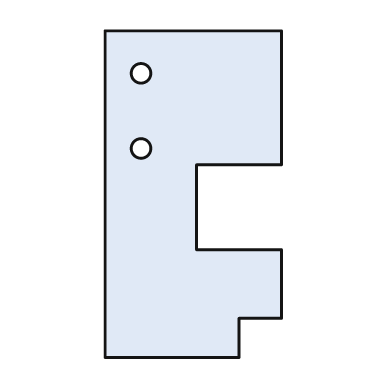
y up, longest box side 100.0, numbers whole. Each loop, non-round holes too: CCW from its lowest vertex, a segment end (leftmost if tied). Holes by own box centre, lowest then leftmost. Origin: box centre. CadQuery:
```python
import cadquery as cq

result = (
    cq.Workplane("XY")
    .moveTo(-27.0, -50.0)
    .lineTo(14.0, -50.0)
    .lineTo(14.0, -38.0)
    .lineTo(27.0, -38.0)
    .lineTo(27.0, -17.0)
    .lineTo(1.0, -17.0)
    .lineTo(1.0, 9.0)
    .lineTo(27.0, 9.0)
    .lineTo(27.0, 50.0)
    .lineTo(-27.0, 50.0)
    .close()
    .moveTo(-16.0, 14.0)
    .circle(3.0)
    .moveTo(-16.0, 37.0)
    .circle(3.0)
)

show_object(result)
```